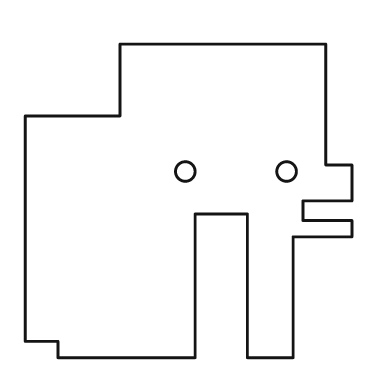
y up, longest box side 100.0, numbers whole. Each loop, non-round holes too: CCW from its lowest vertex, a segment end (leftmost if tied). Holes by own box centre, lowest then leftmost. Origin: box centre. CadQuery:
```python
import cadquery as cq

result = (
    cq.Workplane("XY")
    .moveTo(-40.0, -48.0)
    .lineTo(2.0, -48.0)
    .lineTo(2.0, -4.0)
    .lineTo(18.0, -4.0)
    .lineTo(18.0, -48.0)
    .lineTo(32.0, -48.0)
    .lineTo(32.0, -11.0)
    .lineTo(50.0, -11.0)
    .lineTo(50.0, -6.0)
    .lineTo(35.0, -6.0)
    .lineTo(35.0, 0.0)
    .lineTo(50.0, 0.0)
    .lineTo(50.0, 11.0)
    .lineTo(42.0, 11.0)
    .lineTo(42.0, 48.0)
    .lineTo(-21.0, 48.0)
    .lineTo(-21.0, 26.0)
    .lineTo(-50.0, 26.0)
    .lineTo(-50.0, -43.0)
    .lineTo(-40.0, -43.0)
    .close()
    .moveTo(-1.0, 9.0)
    .circle(3.0)
    .moveTo(30.0, 9.0)
    .circle(3.0)
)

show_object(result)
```